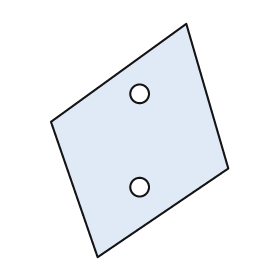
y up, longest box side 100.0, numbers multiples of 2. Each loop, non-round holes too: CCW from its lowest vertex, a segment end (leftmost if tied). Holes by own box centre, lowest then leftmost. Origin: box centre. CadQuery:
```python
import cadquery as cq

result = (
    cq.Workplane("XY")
    .moveTo(-18.0, -50.0)
    .lineTo(38.0, -12.0)
    .lineTo(20.0, 50.0)
    .lineTo(-38.0, 8.0)
    .close()
    .moveTo(0.0, -20.0)
    .circle(4.0)
    .moveTo(0.0, 20.0)
    .circle(4.0)
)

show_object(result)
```